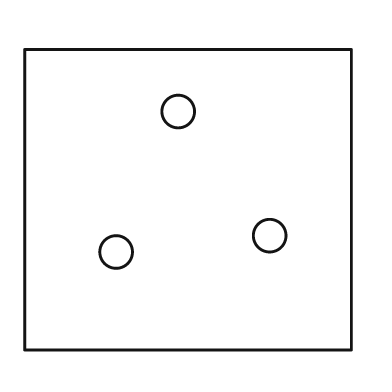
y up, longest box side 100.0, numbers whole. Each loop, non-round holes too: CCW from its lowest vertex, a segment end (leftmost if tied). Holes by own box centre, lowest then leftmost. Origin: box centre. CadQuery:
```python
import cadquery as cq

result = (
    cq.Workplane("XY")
    .moveTo(-50.0, -46.0)
    .lineTo(50.0, -46.0)
    .lineTo(50.0, 46.0)
    .lineTo(-50.0, 46.0)
    .close()
    .moveTo(-22.0, -16.0)
    .circle(5.0)
    .moveTo(25.0, -11.0)
    .circle(5.0)
    .moveTo(-3.0, 27.0)
    .circle(5.0)
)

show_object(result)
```